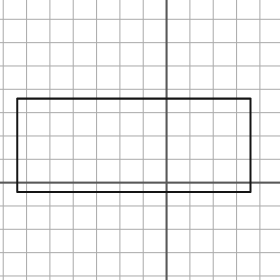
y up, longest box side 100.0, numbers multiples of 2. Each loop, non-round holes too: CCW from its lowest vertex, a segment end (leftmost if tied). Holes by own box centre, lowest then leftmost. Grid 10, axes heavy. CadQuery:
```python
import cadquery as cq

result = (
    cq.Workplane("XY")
    .moveTo(-64.0, -4.0)
    .lineTo(36.0, -4.0)
    .lineTo(36.0, 36.0)
    .lineTo(-64.0, 36.0)
    .close()
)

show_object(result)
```